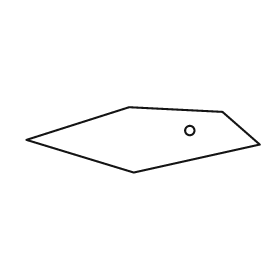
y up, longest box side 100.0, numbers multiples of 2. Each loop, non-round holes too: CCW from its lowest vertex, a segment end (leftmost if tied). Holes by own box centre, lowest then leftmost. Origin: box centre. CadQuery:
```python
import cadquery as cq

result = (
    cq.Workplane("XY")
    .moveTo(-4.0, -14.0)
    .lineTo(50.0, -2.0)
    .lineTo(34.0, 12.0)
    .lineTo(-6.0, 14.0)
    .lineTo(-50.0, 0.0)
    .close()
    .moveTo(20.0, 4.0)
    .circle(2.0)
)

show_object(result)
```